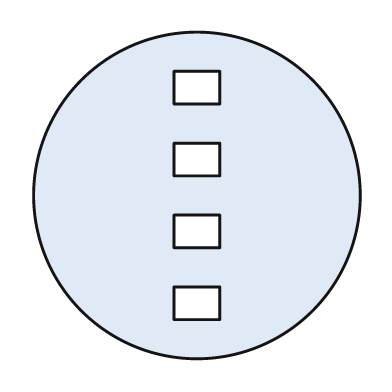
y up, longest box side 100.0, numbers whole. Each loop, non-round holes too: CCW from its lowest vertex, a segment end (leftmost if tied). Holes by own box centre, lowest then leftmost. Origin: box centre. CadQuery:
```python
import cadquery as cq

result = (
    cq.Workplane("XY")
    .moveTo(0.0, 0.0)
    .circle(50.0)
    .moveTo(-7.0, -38.0)
    .lineTo(7.0, -38.0)
    .lineTo(7.0, -28.0)
    .lineTo(-7.0, -28.0)
    .close()
    .moveTo(-7.0, -16.0)
    .lineTo(7.0, -16.0)
    .lineTo(7.0, -6.0)
    .lineTo(-7.0, -6.0)
    .close()
    .moveTo(-7.0, 6.0)
    .lineTo(7.0, 6.0)
    .lineTo(7.0, 16.0)
    .lineTo(-7.0, 16.0)
    .close()
    .moveTo(-7.0, 28.0)
    .lineTo(7.0, 28.0)
    .lineTo(7.0, 38.0)
    .lineTo(-7.0, 38.0)
    .close()
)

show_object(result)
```